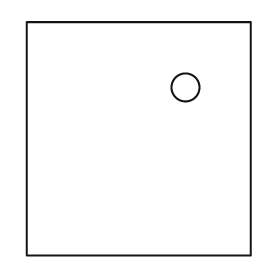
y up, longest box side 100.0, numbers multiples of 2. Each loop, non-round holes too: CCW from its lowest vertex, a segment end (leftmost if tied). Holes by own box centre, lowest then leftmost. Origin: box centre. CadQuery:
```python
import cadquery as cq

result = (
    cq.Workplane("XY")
    .moveTo(-48.0, -50.0)
    .lineTo(48.0, -50.0)
    .lineTo(48.0, 50.0)
    .lineTo(-48.0, 50.0)
    .close()
    .moveTo(20.0, 22.0)
    .circle(6.0)
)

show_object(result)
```